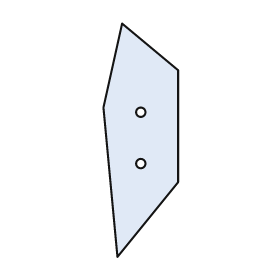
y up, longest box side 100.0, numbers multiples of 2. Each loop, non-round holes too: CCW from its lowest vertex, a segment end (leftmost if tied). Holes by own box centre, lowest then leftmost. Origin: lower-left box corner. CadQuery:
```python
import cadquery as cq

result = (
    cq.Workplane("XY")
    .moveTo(6.0, 0.0)
    .lineTo(32.0, 32.0)
    .lineTo(32.0, 80.0)
    .lineTo(8.0, 100.0)
    .lineTo(0.0, 64.0)
    .close()
    .moveTo(16.0, 40.0)
    .circle(2.0)
    .moveTo(16.0, 62.0)
    .circle(2.0)
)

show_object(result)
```